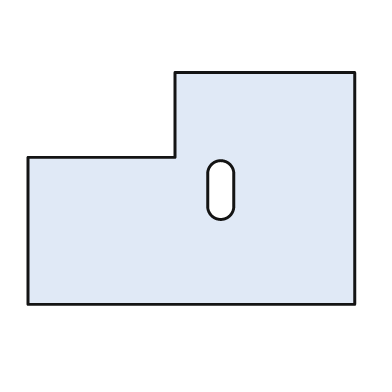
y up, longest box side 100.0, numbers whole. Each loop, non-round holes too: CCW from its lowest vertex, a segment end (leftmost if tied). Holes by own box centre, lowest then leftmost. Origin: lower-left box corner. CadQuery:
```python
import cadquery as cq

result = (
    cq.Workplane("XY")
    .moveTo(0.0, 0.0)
    .lineTo(100.0, 0.0)
    .lineTo(100.0, 71.0)
    .lineTo(45.0, 71.0)
    .lineTo(45.0, 45.0)
    .lineTo(0.0, 45.0)
    .close()
    .moveTo(55.0, 30.0)
    .threePointArc((59.0, 26.0), (63.0, 30.0))
    .lineTo(63.0, 40.0)
    .threePointArc((59.0, 44.0), (55.0, 40.0))
    .close()
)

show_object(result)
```